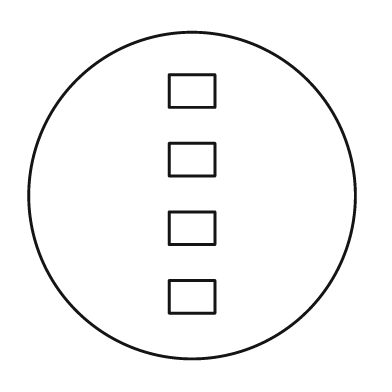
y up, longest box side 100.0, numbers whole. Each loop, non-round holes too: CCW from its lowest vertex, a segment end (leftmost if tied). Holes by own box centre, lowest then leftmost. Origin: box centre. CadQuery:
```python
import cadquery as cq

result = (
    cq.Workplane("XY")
    .moveTo(0.0, 0.0)
    .circle(50.0)
    .moveTo(-7.0, -36.0)
    .lineTo(7.0, -36.0)
    .lineTo(7.0, -26.0)
    .lineTo(-7.0, -26.0)
    .close()
    .moveTo(-7.0, -15.0)
    .lineTo(7.0, -15.0)
    .lineTo(7.0, -5.0)
    .lineTo(-7.0, -5.0)
    .close()
    .moveTo(-7.0, 6.0)
    .lineTo(7.0, 6.0)
    .lineTo(7.0, 16.0)
    .lineTo(-7.0, 16.0)
    .close()
    .moveTo(-7.0, 27.0)
    .lineTo(7.0, 27.0)
    .lineTo(7.0, 37.0)
    .lineTo(-7.0, 37.0)
    .close()
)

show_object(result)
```